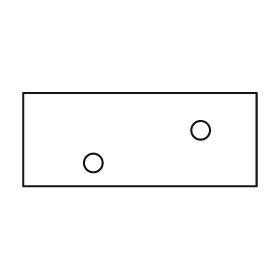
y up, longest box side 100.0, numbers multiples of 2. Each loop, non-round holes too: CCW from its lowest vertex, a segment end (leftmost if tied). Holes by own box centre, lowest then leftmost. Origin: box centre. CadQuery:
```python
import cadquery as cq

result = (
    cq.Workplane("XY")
    .moveTo(-50.0, -20.0)
    .lineTo(50.0, -20.0)
    .lineTo(50.0, 20.0)
    .lineTo(-50.0, 20.0)
    .close()
    .moveTo(-20.0, -10.0)
    .circle(4.0)
    .moveTo(26.0, 4.0)
    .circle(4.0)
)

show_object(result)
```